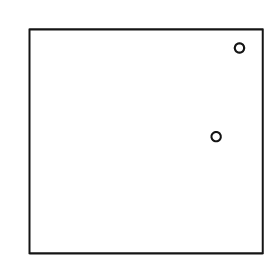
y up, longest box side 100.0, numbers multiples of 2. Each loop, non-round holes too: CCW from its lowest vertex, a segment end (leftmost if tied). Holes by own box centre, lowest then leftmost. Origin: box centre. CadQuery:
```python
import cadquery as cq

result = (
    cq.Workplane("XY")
    .moveTo(-50.0, -48.0)
    .lineTo(50.0, -48.0)
    .lineTo(50.0, 48.0)
    .lineTo(-50.0, 48.0)
    .close()
    .moveTo(30.0, 2.0)
    .circle(2.0)
    .moveTo(40.0, 40.0)
    .circle(2.0)
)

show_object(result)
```